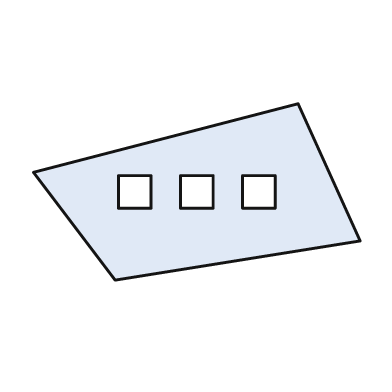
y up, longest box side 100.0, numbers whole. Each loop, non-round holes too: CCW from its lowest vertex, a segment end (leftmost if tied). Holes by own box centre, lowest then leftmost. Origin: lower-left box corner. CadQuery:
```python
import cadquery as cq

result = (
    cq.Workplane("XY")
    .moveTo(25.0, 0.0)
    .lineTo(100.0, 12.0)
    .lineTo(81.0, 54.0)
    .lineTo(0.0, 33.0)
    .close()
    .moveTo(26.0, 22.0)
    .lineTo(36.0, 22.0)
    .lineTo(36.0, 32.0)
    .lineTo(26.0, 32.0)
    .close()
    .moveTo(45.0, 22.0)
    .lineTo(55.0, 22.0)
    .lineTo(55.0, 32.0)
    .lineTo(45.0, 32.0)
    .close()
    .moveTo(64.0, 22.0)
    .lineTo(74.0, 22.0)
    .lineTo(74.0, 32.0)
    .lineTo(64.0, 32.0)
    .close()
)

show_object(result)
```